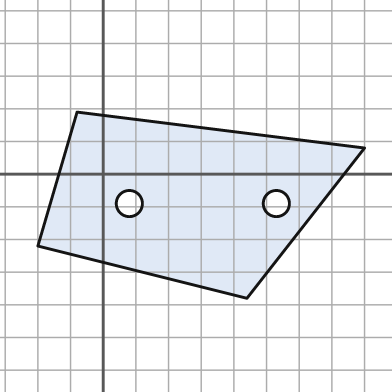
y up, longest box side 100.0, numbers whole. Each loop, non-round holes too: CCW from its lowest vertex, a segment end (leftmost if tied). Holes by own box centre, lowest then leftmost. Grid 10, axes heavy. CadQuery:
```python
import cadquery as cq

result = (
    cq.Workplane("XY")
    .moveTo(44.0, -38.0)
    .lineTo(80.0, 8.0)
    .lineTo(-8.0, 19.0)
    .lineTo(-20.0, -22.0)
    .close()
    .moveTo(8.0, -9.0)
    .circle(4.0)
    .moveTo(53.0, -9.0)
    .circle(4.0)
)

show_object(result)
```